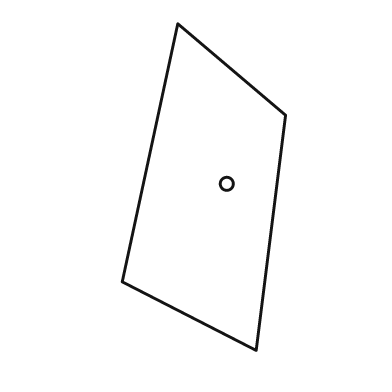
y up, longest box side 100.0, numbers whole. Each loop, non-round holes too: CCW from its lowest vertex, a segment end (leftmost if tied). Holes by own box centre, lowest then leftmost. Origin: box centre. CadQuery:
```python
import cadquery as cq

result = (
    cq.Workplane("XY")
    .moveTo(16.0, -50.0)
    .lineTo(25.0, 22.0)
    .lineTo(-8.0, 50.0)
    .lineTo(-25.0, -29.0)
    .close()
    .moveTo(7.0, 1.0)
    .circle(2.0)
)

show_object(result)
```